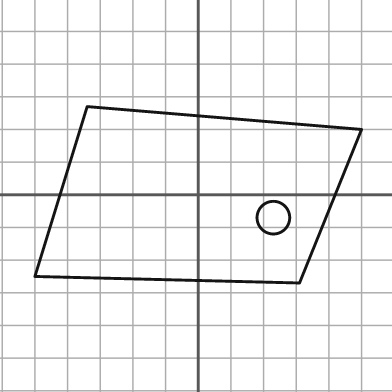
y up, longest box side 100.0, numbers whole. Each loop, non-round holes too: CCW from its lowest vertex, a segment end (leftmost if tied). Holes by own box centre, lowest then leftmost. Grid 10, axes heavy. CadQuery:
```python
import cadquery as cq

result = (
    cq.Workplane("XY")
    .moveTo(31.0, -27.0)
    .lineTo(50.0, 20.0)
    .lineTo(-34.0, 27.0)
    .lineTo(-50.0, -25.0)
    .close()
    .moveTo(23.0, -7.0)
    .circle(5.0)
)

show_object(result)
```